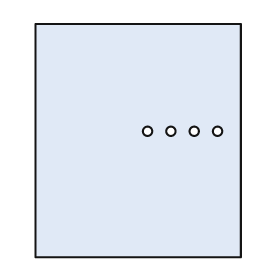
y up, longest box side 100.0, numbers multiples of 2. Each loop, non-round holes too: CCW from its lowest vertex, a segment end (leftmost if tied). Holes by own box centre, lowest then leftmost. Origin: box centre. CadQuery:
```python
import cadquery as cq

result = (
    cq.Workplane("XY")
    .moveTo(-44.0, -50.0)
    .lineTo(44.0, -50.0)
    .lineTo(44.0, 50.0)
    .lineTo(-44.0, 50.0)
    .close()
    .moveTo(4.0, 4.0)
    .circle(2.0)
    .moveTo(14.0, 4.0)
    .circle(2.0)
    .moveTo(24.0, 4.0)
    .circle(2.0)
    .moveTo(34.0, 4.0)
    .circle(2.0)
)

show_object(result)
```